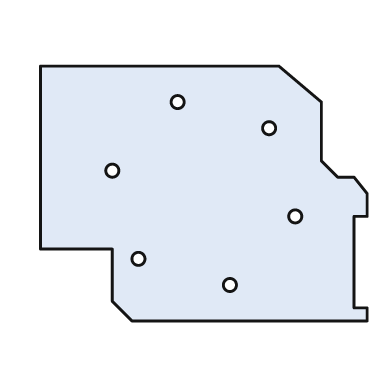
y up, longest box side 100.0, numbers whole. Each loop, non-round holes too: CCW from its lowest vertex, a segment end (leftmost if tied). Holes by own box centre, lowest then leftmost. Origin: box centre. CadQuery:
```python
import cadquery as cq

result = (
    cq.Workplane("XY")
    .moveTo(-22.0, -39.0)
    .lineTo(50.0, -39.0)
    .lineTo(50.0, -35.0)
    .lineTo(46.0, -35.0)
    .lineTo(46.0, -7.0)
    .lineTo(50.0, -7.0)
    .lineTo(50.0, 0.0)
    .lineTo(46.0, 5.0)
    .lineTo(41.0, 5.0)
    .lineTo(36.0, 10.0)
    .lineTo(36.0, 28.0)
    .lineTo(23.0, 39.0)
    .lineTo(-50.0, 39.0)
    .lineTo(-50.0, -17.0)
    .lineTo(-28.0, -17.0)
    .lineTo(-28.0, -33.0)
    .close()
    .moveTo(8.0, -28.0)
    .circle(2.0)
    .moveTo(-20.0, -20.0)
    .circle(2.0)
    .moveTo(28.0, -7.0)
    .circle(2.0)
    .moveTo(-28.0, 7.0)
    .circle(2.0)
    .moveTo(20.0, 20.0)
    .circle(2.0)
    .moveTo(-8.0, 28.0)
    .circle(2.0)
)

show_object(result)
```